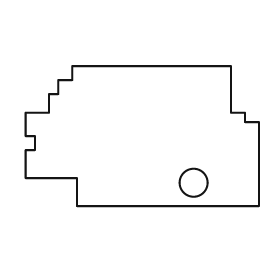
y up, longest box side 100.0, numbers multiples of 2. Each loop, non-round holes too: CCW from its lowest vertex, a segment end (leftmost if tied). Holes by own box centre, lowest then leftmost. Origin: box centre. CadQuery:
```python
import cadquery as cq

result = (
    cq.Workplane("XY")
    .moveTo(-28.0, -30.0)
    .lineTo(50.0, -30.0)
    .lineTo(50.0, 6.0)
    .lineTo(44.0, 6.0)
    .lineTo(44.0, 10.0)
    .lineTo(38.0, 10.0)
    .lineTo(38.0, 30.0)
    .lineTo(-30.0, 30.0)
    .lineTo(-30.0, 24.0)
    .lineTo(-36.0, 24.0)
    .lineTo(-36.0, 18.0)
    .lineTo(-40.0, 18.0)
    .lineTo(-40.0, 10.0)
    .lineTo(-50.0, 10.0)
    .lineTo(-50.0, 0.0)
    .lineTo(-46.0, 0.0)
    .lineTo(-46.0, -6.0)
    .lineTo(-50.0, -6.0)
    .lineTo(-50.0, -18.0)
    .lineTo(-28.0, -18.0)
    .close()
    .moveTo(22.0, -20.0)
    .circle(6.0)
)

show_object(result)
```